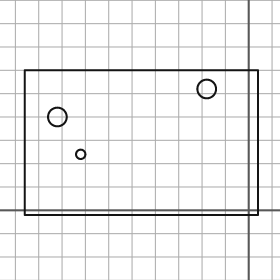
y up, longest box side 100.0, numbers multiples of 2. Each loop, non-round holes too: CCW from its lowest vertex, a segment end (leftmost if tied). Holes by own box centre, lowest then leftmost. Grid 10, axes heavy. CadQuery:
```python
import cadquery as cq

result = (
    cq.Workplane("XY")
    .moveTo(-96.0, -2.0)
    .lineTo(4.0, -2.0)
    .lineTo(4.0, 60.0)
    .lineTo(-96.0, 60.0)
    .close()
    .moveTo(-72.0, 24.0)
    .circle(2.0)
    .moveTo(-82.0, 40.0)
    .circle(4.0)
    .moveTo(-18.0, 52.0)
    .circle(4.0)
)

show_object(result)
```